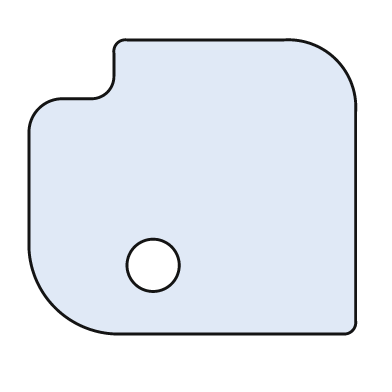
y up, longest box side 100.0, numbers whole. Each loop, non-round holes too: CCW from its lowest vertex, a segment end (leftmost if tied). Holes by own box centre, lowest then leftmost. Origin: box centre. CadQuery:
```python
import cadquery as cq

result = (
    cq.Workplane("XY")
    .moveTo(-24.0, -45.0)
    .lineTo(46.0, -45.0)
    .threePointArc((49.0, -44.0), (50.0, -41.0))
    .lineTo(50.0, 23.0)
    .threePointArc((44.0, 39.0), (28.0, 45.0))
    .lineTo(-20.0, 45.0)
    .threePointArc((-23.0, 44.0), (-24.0, 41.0))
    .lineTo(-24.0, 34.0)
    .threePointArc((-26.0, 29.0), (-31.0, 27.0))
    .lineTo(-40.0, 27.0)
    .threePointArc((-47.0, 24.0), (-50.0, 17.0))
    .lineTo(-50.0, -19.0)
    .threePointArc((-42.0, -37.0), (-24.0, -45.0))
    .close()
    .moveTo(-12.0, -24.0)
    .circle(8.0)
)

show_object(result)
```